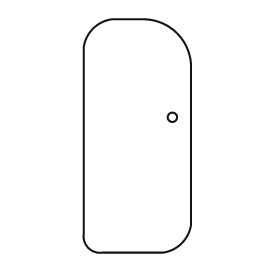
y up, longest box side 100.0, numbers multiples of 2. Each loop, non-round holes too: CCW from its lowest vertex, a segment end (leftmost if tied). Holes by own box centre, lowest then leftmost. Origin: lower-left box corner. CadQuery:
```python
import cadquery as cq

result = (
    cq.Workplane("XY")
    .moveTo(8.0, 0.0)
    .lineTo(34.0, 0.0)
    .threePointArc((42.0, 4.0), (46.0, 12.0))
    .lineTo(46.0, 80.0)
    .threePointArc((40.0, 94.0), (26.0, 100.0))
    .lineTo(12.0, 100.0)
    .threePointArc((4.0, 96.0), (0.0, 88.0))
    .lineTo(0.0, 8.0)
    .threePointArc((2.0, 2.0), (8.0, 0.0))
    .close()
    .moveTo(38.0, 58.0)
    .circle(2.0)
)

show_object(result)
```